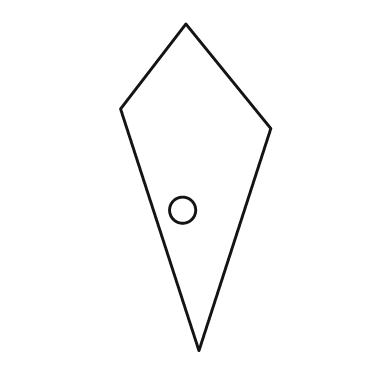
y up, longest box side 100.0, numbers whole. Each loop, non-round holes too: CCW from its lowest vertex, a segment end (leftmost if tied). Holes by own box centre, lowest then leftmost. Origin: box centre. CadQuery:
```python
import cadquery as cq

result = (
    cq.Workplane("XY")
    .moveTo(1.0, -50.0)
    .lineTo(23.0, 18.0)
    .lineTo(-3.0, 50.0)
    .lineTo(-23.0, 24.0)
    .close()
    .moveTo(-4.0, -7.0)
    .circle(4.0)
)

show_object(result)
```